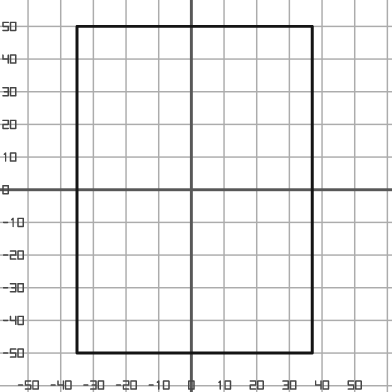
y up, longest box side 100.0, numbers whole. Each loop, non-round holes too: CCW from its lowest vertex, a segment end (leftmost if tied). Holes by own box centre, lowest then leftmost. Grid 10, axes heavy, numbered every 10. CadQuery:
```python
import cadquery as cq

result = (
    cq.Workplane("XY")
    .moveTo(-35.0, -50.0)
    .lineTo(37.0, -50.0)
    .lineTo(37.0, 50.0)
    .lineTo(-35.0, 50.0)
    .close()
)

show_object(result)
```